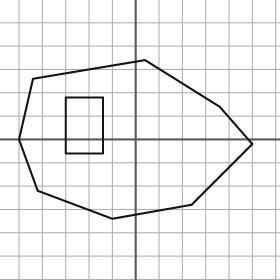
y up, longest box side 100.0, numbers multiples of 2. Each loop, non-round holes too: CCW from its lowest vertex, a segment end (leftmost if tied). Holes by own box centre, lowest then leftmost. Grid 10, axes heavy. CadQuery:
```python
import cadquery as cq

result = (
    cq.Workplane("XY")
    .moveTo(-10.0, -34.0)
    .lineTo(24.0, -28.0)
    .lineTo(50.0, -2.0)
    .lineTo(36.0, 14.0)
    .lineTo(4.0, 34.0)
    .lineTo(-44.0, 26.0)
    .lineTo(-50.0, 0.0)
    .lineTo(-42.0, -22.0)
    .close()
    .moveTo(-30.0, -6.0)
    .lineTo(-14.0, -6.0)
    .lineTo(-14.0, 18.0)
    .lineTo(-30.0, 18.0)
    .close()
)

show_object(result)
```